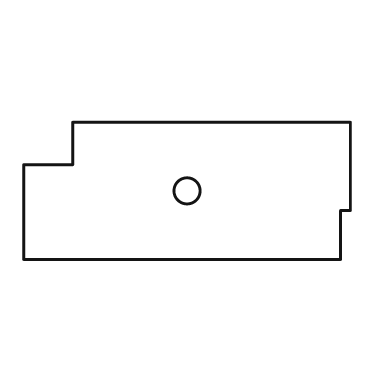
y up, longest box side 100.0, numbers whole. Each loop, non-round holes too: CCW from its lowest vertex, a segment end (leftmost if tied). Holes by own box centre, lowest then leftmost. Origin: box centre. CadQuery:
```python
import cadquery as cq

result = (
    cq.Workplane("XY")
    .moveTo(-50.0, -21.0)
    .lineTo(47.0, -21.0)
    .lineTo(47.0, -6.0)
    .lineTo(50.0, -6.0)
    .lineTo(50.0, 21.0)
    .lineTo(-35.0, 21.0)
    .lineTo(-35.0, 8.0)
    .lineTo(-50.0, 8.0)
    .close()
    .moveTo(0.0, 0.0)
    .circle(4.0)
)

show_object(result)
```